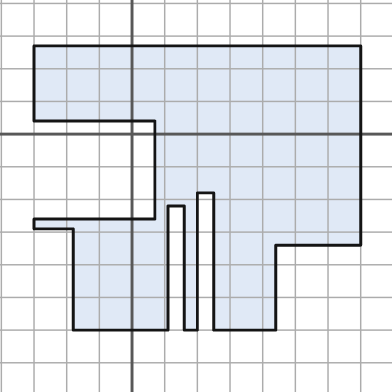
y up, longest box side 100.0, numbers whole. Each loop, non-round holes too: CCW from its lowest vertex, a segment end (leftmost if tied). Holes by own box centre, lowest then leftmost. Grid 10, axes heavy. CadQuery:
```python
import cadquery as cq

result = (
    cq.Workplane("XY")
    .moveTo(-18.0, -60.0)
    .lineTo(11.0, -60.0)
    .lineTo(11.0, -22.0)
    .lineTo(16.0, -22.0)
    .lineTo(16.0, -60.0)
    .lineTo(20.0, -60.0)
    .lineTo(20.0, -18.0)
    .lineTo(25.0, -18.0)
    .lineTo(25.0, -60.0)
    .lineTo(44.0, -60.0)
    .lineTo(44.0, -34.0)
    .lineTo(70.0, -34.0)
    .lineTo(70.0, 27.0)
    .lineTo(-30.0, 27.0)
    .lineTo(-30.0, 4.0)
    .lineTo(7.0, 4.0)
    .lineTo(7.0, -26.0)
    .lineTo(-30.0, -26.0)
    .lineTo(-30.0, -29.0)
    .lineTo(-18.0, -29.0)
    .close()
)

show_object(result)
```